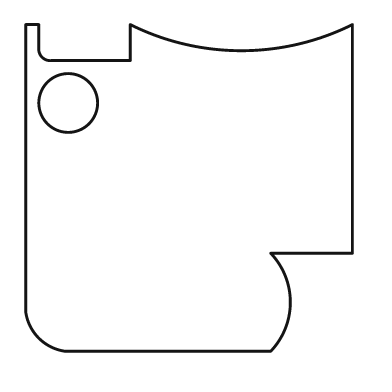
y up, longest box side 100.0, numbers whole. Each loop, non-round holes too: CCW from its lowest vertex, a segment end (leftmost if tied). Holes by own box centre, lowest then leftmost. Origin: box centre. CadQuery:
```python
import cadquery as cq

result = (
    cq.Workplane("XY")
    .moveTo(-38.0, -50.0)
    .lineTo(25.0, -50.0)
    .threePointArc((31.0, -35.0), (25.0, -20.0))
    .lineTo(50.0, -20.0)
    .lineTo(50.0, 50.0)
    .threePointArc((16.0, 42.0), (-18.0, 50.0))
    .lineTo(-18.0, 39.0)
    .lineTo(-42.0, 39.0)
    .threePointArc((-45.0, 40.0), (-46.0, 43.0))
    .lineTo(-46.0, 50.0)
    .lineTo(-50.0, 50.0)
    .lineTo(-50.0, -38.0)
    .threePointArc((-46.0, -46.0), (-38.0, -50.0))
    .close()
    .moveTo(-37.0, 26.0)
    .circle(9.0)
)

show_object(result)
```